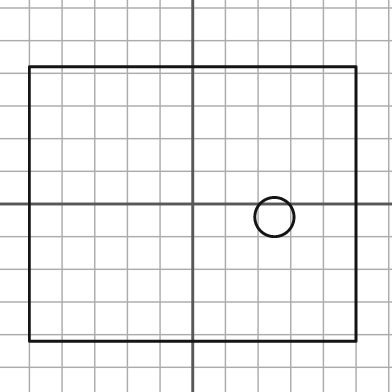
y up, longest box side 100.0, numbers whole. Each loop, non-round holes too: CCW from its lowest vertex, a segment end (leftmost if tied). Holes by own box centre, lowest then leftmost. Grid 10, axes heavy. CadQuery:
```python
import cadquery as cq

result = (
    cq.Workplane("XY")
    .moveTo(-50.0, -42.0)
    .lineTo(50.0, -42.0)
    .lineTo(50.0, 42.0)
    .lineTo(-50.0, 42.0)
    .close()
    .moveTo(25.0, -4.0)
    .circle(6.0)
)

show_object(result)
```